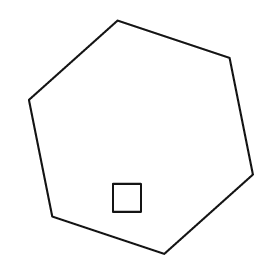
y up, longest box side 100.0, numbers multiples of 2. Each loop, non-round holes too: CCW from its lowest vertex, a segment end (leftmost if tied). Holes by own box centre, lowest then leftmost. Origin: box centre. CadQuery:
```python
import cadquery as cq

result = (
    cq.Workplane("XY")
    .moveTo(10.0, -50.0)
    .lineTo(48.0, -16.0)
    .lineTo(38.0, 34.0)
    .lineTo(-10.0, 50.0)
    .lineTo(-48.0, 16.0)
    .lineTo(-38.0, -34.0)
    .close()
    .moveTo(-12.0, -32.0)
    .lineTo(0.0, -32.0)
    .lineTo(0.0, -20.0)
    .lineTo(-12.0, -20.0)
    .close()
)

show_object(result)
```